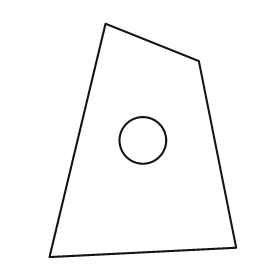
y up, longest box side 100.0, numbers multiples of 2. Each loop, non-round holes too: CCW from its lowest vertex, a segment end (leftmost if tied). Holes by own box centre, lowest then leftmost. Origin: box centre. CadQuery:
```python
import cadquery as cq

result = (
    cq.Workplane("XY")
    .moveTo(-40.0, -50.0)
    .lineTo(40.0, -46.0)
    .lineTo(24.0, 34.0)
    .lineTo(-16.0, 50.0)
    .close()
    .moveTo(0.0, 0.0)
    .circle(10.0)
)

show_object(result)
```